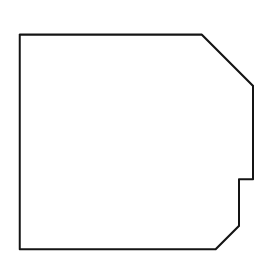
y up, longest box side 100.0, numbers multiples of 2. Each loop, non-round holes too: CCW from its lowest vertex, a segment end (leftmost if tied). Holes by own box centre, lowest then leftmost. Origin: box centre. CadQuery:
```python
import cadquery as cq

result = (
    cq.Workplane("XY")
    .moveTo(-50.0, -46.0)
    .lineTo(34.0, -46.0)
    .lineTo(44.0, -36.0)
    .lineTo(44.0, -16.0)
    .lineTo(50.0, -16.0)
    .lineTo(50.0, 24.0)
    .lineTo(28.0, 46.0)
    .lineTo(-50.0, 46.0)
    .close()
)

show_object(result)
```